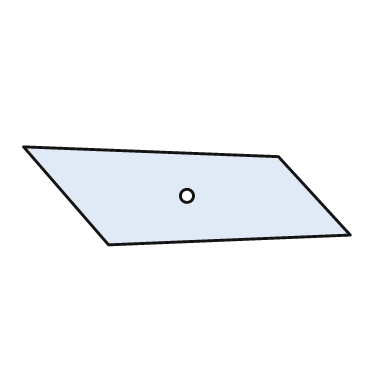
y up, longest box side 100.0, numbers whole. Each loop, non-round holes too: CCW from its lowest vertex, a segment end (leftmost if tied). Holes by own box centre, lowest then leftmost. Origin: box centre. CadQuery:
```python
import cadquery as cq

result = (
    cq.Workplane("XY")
    .moveTo(-24.0, -15.0)
    .lineTo(50.0, -12.0)
    .lineTo(28.0, 12.0)
    .lineTo(-50.0, 15.0)
    .close()
    .moveTo(0.0, 0.0)
    .circle(2.0)
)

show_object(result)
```